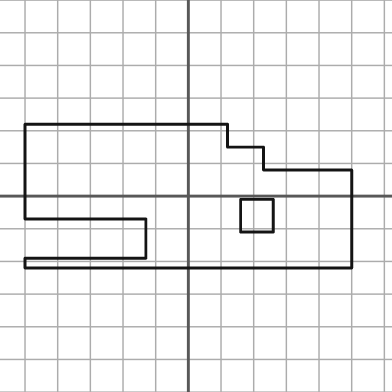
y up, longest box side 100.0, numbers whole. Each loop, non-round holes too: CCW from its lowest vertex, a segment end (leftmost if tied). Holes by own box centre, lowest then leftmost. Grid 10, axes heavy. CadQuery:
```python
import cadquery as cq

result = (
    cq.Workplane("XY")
    .moveTo(-50.0, -22.0)
    .lineTo(50.0, -22.0)
    .lineTo(50.0, 8.0)
    .lineTo(23.0, 8.0)
    .lineTo(23.0, 15.0)
    .lineTo(12.0, 15.0)
    .lineTo(12.0, 22.0)
    .lineTo(-50.0, 22.0)
    .lineTo(-50.0, -7.0)
    .lineTo(-13.0, -7.0)
    .lineTo(-13.0, -19.0)
    .lineTo(-50.0, -19.0)
    .close()
    .moveTo(16.0, -11.0)
    .lineTo(26.0, -11.0)
    .lineTo(26.0, -1.0)
    .lineTo(16.0, -1.0)
    .close()
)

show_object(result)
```